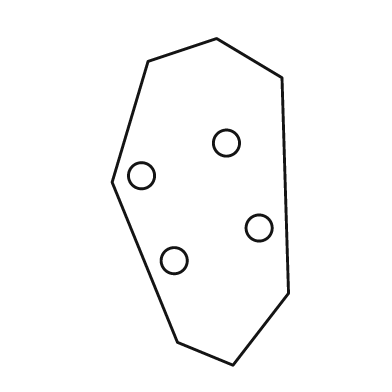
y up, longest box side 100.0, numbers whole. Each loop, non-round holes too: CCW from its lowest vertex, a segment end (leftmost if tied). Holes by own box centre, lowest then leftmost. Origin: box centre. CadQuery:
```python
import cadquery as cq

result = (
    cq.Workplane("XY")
    .moveTo(10.0, -50.0)
    .lineTo(27.0, -28.0)
    .lineTo(25.0, 38.0)
    .lineTo(5.0, 50.0)
    .lineTo(-16.0, 43.0)
    .lineTo(-27.0, 6.0)
    .lineTo(-7.0, -43.0)
    .close()
    .moveTo(-8.0, -18.0)
    .circle(4.0)
    .moveTo(18.0, -8.0)
    .circle(4.0)
    .moveTo(-18.0, 8.0)
    .circle(4.0)
    .moveTo(8.0, 18.0)
    .circle(4.0)
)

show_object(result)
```